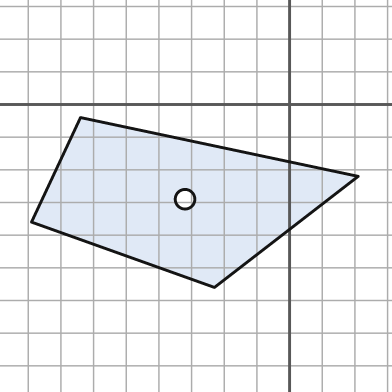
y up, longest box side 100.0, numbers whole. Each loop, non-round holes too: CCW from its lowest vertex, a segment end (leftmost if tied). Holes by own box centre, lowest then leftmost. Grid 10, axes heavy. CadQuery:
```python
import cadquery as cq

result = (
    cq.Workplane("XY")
    .moveTo(-23.0, -56.0)
    .lineTo(21.0, -22.0)
    .lineTo(-64.0, -4.0)
    .lineTo(-79.0, -36.0)
    .close()
    .moveTo(-32.0, -29.0)
    .circle(3.0)
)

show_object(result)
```